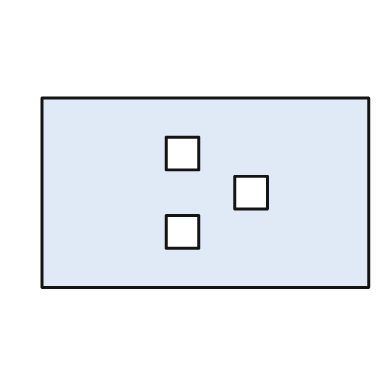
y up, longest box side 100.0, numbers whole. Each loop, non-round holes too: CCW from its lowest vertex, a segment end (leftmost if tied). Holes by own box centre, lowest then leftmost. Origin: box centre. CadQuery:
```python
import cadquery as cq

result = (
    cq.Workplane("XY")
    .moveTo(-50.0, -29.0)
    .lineTo(50.0, -29.0)
    .lineTo(50.0, 29.0)
    .lineTo(-50.0, 29.0)
    .close()
    .moveTo(-12.0, -17.0)
    .lineTo(-2.0, -17.0)
    .lineTo(-2.0, -7.0)
    .lineTo(-12.0, -7.0)
    .close()
    .moveTo(9.0, -5.0)
    .lineTo(19.0, -5.0)
    .lineTo(19.0, 5.0)
    .lineTo(9.0, 5.0)
    .close()
    .moveTo(-12.0, 7.0)
    .lineTo(-2.0, 7.0)
    .lineTo(-2.0, 17.0)
    .lineTo(-12.0, 17.0)
    .close()
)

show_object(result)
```